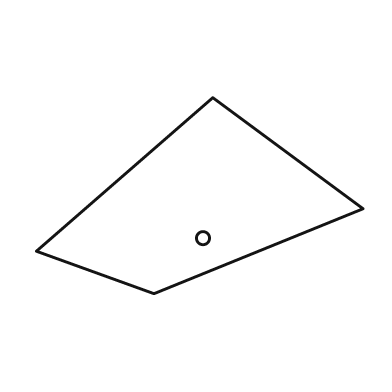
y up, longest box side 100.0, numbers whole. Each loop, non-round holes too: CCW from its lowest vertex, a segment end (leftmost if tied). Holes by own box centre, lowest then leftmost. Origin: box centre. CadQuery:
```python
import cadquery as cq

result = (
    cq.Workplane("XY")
    .moveTo(-14.0, -30.0)
    .lineTo(50.0, -4.0)
    .lineTo(4.0, 30.0)
    .lineTo(-50.0, -17.0)
    .close()
    .moveTo(1.0, -13.0)
    .circle(2.0)
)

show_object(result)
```